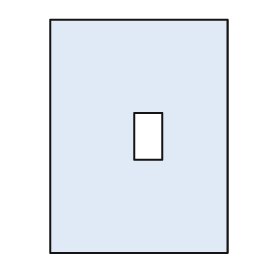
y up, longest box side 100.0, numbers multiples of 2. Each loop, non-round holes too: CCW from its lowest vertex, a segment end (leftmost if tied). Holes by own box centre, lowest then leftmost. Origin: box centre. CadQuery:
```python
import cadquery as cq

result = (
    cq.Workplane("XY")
    .moveTo(-38.0, -50.0)
    .lineTo(38.0, -50.0)
    .lineTo(38.0, 50.0)
    .lineTo(-38.0, 50.0)
    .close()
    .moveTo(-2.0, -10.0)
    .lineTo(10.0, -10.0)
    .lineTo(10.0, 10.0)
    .lineTo(-2.0, 10.0)
    .close()
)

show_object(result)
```